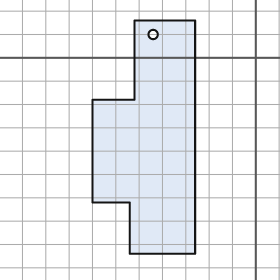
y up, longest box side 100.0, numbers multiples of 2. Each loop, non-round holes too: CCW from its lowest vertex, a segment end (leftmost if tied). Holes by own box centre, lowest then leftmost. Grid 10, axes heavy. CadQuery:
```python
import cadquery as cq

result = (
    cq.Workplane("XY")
    .moveTo(-54.0, -84.0)
    .lineTo(-26.0, -84.0)
    .lineTo(-26.0, 16.0)
    .lineTo(-52.0, 16.0)
    .lineTo(-52.0, -18.0)
    .lineTo(-70.0, -18.0)
    .lineTo(-70.0, -62.0)
    .lineTo(-54.0, -62.0)
    .close()
    .moveTo(-44.0, 10.0)
    .circle(2.0)
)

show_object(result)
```